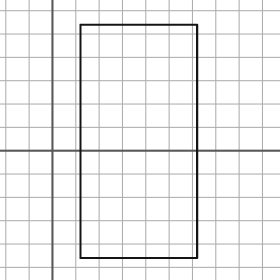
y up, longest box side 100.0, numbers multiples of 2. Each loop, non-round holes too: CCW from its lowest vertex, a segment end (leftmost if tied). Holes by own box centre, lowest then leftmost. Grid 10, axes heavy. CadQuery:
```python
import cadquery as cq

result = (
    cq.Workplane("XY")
    .moveTo(12.0, -46.0)
    .lineTo(62.0, -46.0)
    .lineTo(62.0, 54.0)
    .lineTo(12.0, 54.0)
    .close()
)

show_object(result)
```